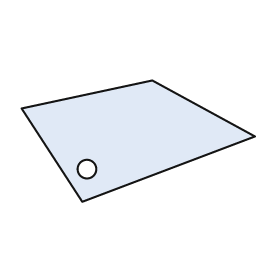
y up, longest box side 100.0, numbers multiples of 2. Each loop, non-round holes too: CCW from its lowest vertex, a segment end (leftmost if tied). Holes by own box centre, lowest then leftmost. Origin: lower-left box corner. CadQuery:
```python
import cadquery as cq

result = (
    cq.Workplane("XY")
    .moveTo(26.0, 0.0)
    .lineTo(100.0, 28.0)
    .lineTo(56.0, 52.0)
    .lineTo(0.0, 40.0)
    .close()
    .moveTo(28.0, 14.0)
    .circle(4.0)
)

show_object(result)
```